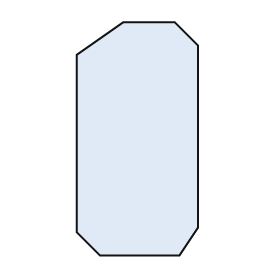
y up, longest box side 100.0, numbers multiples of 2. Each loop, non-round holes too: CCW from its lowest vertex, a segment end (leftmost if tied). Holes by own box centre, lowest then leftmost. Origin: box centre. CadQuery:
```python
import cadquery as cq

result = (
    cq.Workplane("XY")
    .moveTo(-16.0, -50.0)
    .lineTo(18.0, -50.0)
    .lineTo(26.0, -38.0)
    .lineTo(26.0, 40.0)
    .lineTo(16.0, 50.0)
    .lineTo(-6.0, 50.0)
    .lineTo(-26.0, 36.0)
    .lineTo(-26.0, -40.0)
    .close()
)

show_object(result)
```